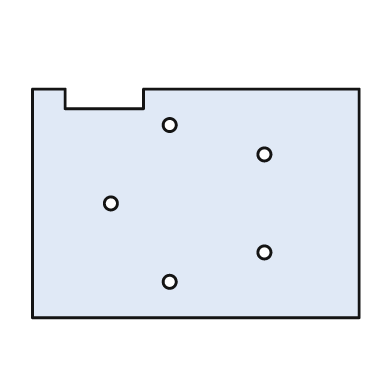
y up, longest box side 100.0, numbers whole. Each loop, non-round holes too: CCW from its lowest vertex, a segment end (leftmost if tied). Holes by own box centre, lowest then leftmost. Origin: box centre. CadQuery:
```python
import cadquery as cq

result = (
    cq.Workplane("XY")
    .moveTo(-50.0, -35.0)
    .lineTo(50.0, -35.0)
    .lineTo(50.0, 35.0)
    .lineTo(-16.0, 35.0)
    .lineTo(-16.0, 29.0)
    .lineTo(-40.0, 29.0)
    .lineTo(-40.0, 35.0)
    .lineTo(-50.0, 35.0)
    .close()
    .moveTo(-8.0, -24.0)
    .circle(2.0)
    .moveTo(21.0, -15.0)
    .circle(2.0)
    .moveTo(-26.0, 0.0)
    .circle(2.0)
    .moveTo(21.0, 15.0)
    .circle(2.0)
    .moveTo(-8.0, 24.0)
    .circle(2.0)
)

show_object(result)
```